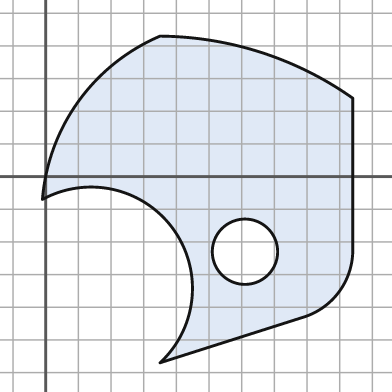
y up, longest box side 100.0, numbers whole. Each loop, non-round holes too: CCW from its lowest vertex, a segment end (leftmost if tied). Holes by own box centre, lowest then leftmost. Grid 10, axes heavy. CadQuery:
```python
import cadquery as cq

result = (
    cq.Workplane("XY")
    .moveTo(35.0, -57.0)
    .lineTo(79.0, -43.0)
    .threePointArc((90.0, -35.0), (94.0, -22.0))
    .lineTo(94.0, 24.0)
    .threePointArc((66.0, 38.0), (35.0, 43.0))
    .threePointArc((10.0, 23.0), (-1.0, -7.0))
    .threePointArc((39.0, -16.0), (35.0, -57.0))
    .close()
    .moveTo(61.0, -23.0)
    .circle(10.0)
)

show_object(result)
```